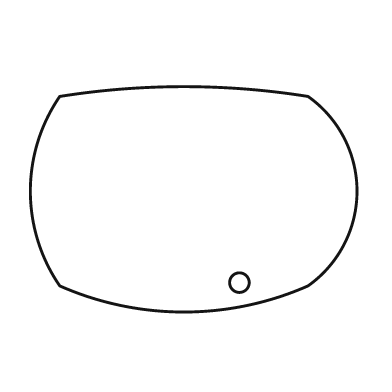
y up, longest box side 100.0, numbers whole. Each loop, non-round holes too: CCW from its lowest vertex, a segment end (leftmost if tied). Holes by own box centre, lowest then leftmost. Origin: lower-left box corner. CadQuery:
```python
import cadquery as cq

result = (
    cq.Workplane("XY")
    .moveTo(9.0, 8.0)
    .threePointArc((47.0, 0.0), (85.0, 8.0))
    .threePointArc((100.0, 37.0), (85.0, 66.0))
    .threePointArc((47.0, 69.0), (9.0, 66.0))
    .threePointArc((0.0, 37.0), (9.0, 8.0))
    .close()
    .moveTo(64.0, 9.0)
    .circle(3.0)
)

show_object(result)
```